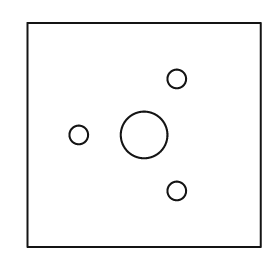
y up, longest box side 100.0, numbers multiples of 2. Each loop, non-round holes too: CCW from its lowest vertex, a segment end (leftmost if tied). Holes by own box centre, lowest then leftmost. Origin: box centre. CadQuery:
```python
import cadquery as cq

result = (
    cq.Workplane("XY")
    .moveTo(-50.0, -48.0)
    .lineTo(50.0, -48.0)
    .lineTo(50.0, 48.0)
    .lineTo(-50.0, 48.0)
    .close()
    .moveTo(14.0, -24.0)
    .circle(4.0)
    .moveTo(-28.0, 0.0)
    .circle(4.0)
    .moveTo(0.0, 0.0)
    .circle(10.0)
    .moveTo(14.0, 24.0)
    .circle(4.0)
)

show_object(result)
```